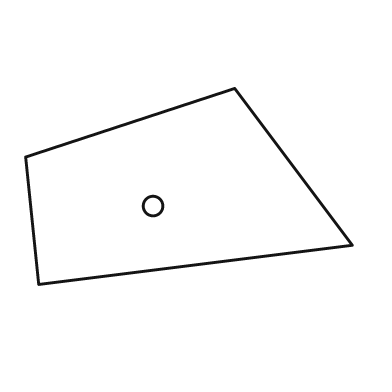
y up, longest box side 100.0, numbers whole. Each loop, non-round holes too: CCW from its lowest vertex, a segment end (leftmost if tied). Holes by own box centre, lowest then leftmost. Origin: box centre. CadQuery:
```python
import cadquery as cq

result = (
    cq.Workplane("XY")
    .moveTo(-46.0, -30.0)
    .lineTo(50.0, -18.0)
    .lineTo(14.0, 30.0)
    .lineTo(-50.0, 9.0)
    .close()
    .moveTo(-11.0, -6.0)
    .circle(3.0)
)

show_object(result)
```